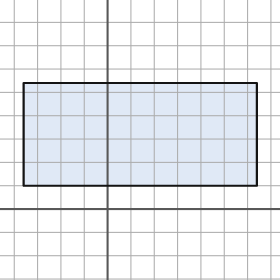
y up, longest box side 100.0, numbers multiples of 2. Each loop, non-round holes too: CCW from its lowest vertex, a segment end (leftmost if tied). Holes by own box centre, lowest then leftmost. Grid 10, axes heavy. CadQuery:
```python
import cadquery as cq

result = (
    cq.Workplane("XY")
    .moveTo(-36.0, 10.0)
    .lineTo(64.0, 10.0)
    .lineTo(64.0, 54.0)
    .lineTo(-36.0, 54.0)
    .close()
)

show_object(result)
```